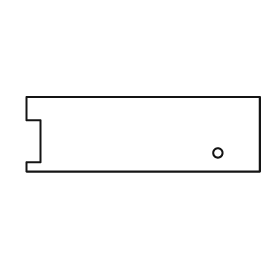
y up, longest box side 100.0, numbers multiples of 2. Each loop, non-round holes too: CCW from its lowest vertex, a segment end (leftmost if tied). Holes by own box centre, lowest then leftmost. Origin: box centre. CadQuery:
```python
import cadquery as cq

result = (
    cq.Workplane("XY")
    .moveTo(-50.0, -16.0)
    .lineTo(50.0, -16.0)
    .lineTo(50.0, 16.0)
    .lineTo(-50.0, 16.0)
    .lineTo(-50.0, 6.0)
    .lineTo(-44.0, 6.0)
    .lineTo(-44.0, -12.0)
    .lineTo(-50.0, -12.0)
    .close()
    .moveTo(32.0, -8.0)
    .circle(2.0)
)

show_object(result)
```